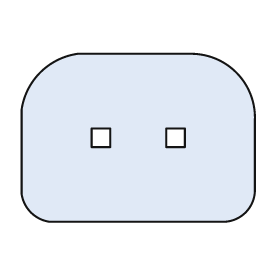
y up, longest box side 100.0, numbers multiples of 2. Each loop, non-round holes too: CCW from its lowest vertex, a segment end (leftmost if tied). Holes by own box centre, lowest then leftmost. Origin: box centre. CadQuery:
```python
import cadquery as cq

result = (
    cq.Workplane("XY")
    .moveTo(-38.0, -36.0)
    .lineTo(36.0, -36.0)
    .threePointArc((46.0, -32.0), (50.0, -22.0))
    .lineTo(50.0, 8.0)
    .threePointArc((42.0, 28.0), (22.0, 36.0))
    .lineTo(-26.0, 36.0)
    .threePointArc((-42.0, 28.0), (-50.0, 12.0))
    .lineTo(-50.0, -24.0)
    .threePointArc((-46.0, -32.0), (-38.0, -36.0))
    .close()
    .moveTo(-20.0, -4.0)
    .lineTo(-12.0, -4.0)
    .lineTo(-12.0, 4.0)
    .lineTo(-20.0, 4.0)
    .close()
    .moveTo(12.0, -4.0)
    .lineTo(20.0, -4.0)
    .lineTo(20.0, 4.0)
    .lineTo(12.0, 4.0)
    .close()
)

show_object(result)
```